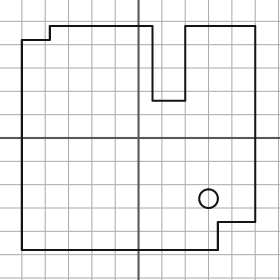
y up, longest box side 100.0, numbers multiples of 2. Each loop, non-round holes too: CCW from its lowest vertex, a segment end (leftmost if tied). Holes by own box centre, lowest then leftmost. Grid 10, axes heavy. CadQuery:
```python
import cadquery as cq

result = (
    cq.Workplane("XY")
    .moveTo(-50.0, -48.0)
    .lineTo(34.0, -48.0)
    .lineTo(34.0, -36.0)
    .lineTo(50.0, -36.0)
    .lineTo(50.0, 48.0)
    .lineTo(20.0, 48.0)
    .lineTo(20.0, 16.0)
    .lineTo(6.0, 16.0)
    .lineTo(6.0, 48.0)
    .lineTo(-38.0, 48.0)
    .lineTo(-38.0, 42.0)
    .lineTo(-50.0, 42.0)
    .close()
    .moveTo(30.0, -26.0)
    .circle(4.0)
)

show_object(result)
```